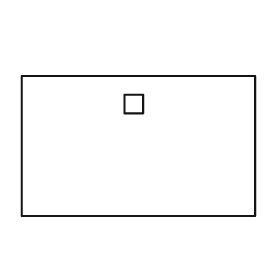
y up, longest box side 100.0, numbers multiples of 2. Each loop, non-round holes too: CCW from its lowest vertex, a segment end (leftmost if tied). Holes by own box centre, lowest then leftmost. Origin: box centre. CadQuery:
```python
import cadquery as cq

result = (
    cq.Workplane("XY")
    .moveTo(-50.0, -30.0)
    .lineTo(50.0, -30.0)
    .lineTo(50.0, 30.0)
    .lineTo(-50.0, 30.0)
    .close()
    .moveTo(-6.0, 14.0)
    .lineTo(2.0, 14.0)
    .lineTo(2.0, 22.0)
    .lineTo(-6.0, 22.0)
    .close()
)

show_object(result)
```